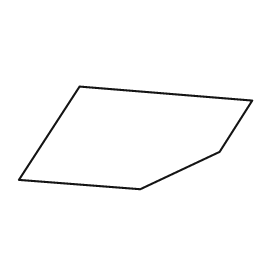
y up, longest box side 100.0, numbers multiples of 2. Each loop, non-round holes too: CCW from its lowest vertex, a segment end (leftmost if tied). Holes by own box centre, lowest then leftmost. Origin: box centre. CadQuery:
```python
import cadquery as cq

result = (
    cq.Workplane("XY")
    .moveTo(2.0, -22.0)
    .lineTo(36.0, -6.0)
    .lineTo(50.0, 16.0)
    .lineTo(-24.0, 22.0)
    .lineTo(-50.0, -18.0)
    .close()
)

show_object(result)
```